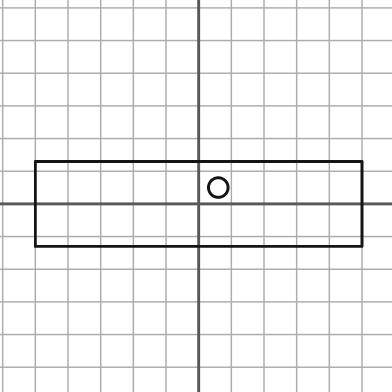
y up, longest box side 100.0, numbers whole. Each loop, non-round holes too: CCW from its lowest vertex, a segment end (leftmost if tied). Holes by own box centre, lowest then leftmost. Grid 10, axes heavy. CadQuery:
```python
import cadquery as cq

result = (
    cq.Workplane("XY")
    .moveTo(-50.0, -13.0)
    .lineTo(50.0, -13.0)
    .lineTo(50.0, 13.0)
    .lineTo(-50.0, 13.0)
    .close()
    .moveTo(6.0, 5.0)
    .circle(3.0)
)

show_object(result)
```